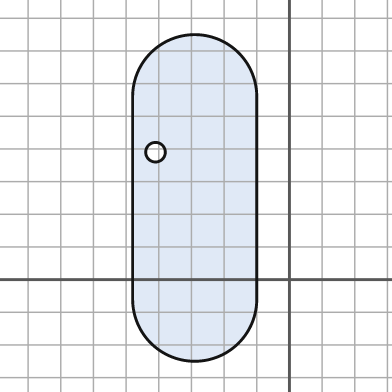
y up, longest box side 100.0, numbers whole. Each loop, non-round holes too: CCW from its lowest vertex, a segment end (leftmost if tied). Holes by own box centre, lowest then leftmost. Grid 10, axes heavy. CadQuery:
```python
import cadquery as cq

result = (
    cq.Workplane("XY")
    .moveTo(-48.0, -6.0)
    .threePointArc((-29.0, -25.0), (-10.0, -6.0))
    .lineTo(-10.0, 56.0)
    .threePointArc((-29.0, 75.0), (-48.0, 56.0))
    .close()
    .moveTo(-41.0, 39.0)
    .circle(3.0)
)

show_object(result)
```